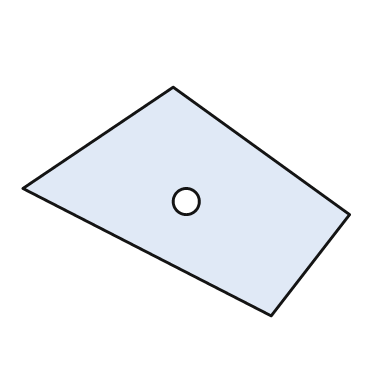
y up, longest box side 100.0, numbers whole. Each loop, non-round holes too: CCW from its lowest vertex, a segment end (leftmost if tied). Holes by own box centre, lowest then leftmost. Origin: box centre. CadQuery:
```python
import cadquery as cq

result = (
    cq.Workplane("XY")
    .moveTo(26.0, -35.0)
    .lineTo(50.0, -4.0)
    .lineTo(-4.0, 35.0)
    .lineTo(-50.0, 4.0)
    .close()
    .moveTo(0.0, 0.0)
    .circle(4.0)
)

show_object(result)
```